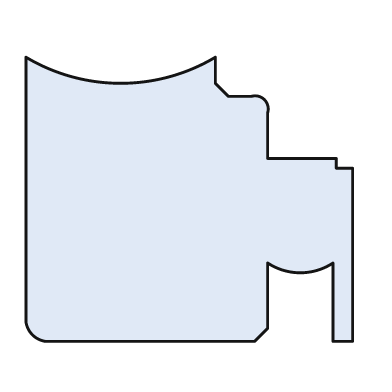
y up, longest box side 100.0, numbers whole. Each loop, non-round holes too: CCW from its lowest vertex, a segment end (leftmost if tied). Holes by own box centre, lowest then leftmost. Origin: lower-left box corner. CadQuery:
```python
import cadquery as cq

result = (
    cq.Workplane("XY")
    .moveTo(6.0, 0.0)
    .lineTo(70.0, 0.0)
    .lineTo(74.0, 4.0)
    .lineTo(74.0, 24.0)
    .threePointArc((84.0, 21.0), (94.0, 24.0))
    .lineTo(94.0, 0.0)
    .lineTo(100.0, 0.0)
    .lineTo(100.0, 53.0)
    .lineTo(95.0, 53.0)
    .lineTo(95.0, 56.0)
    .lineTo(74.0, 56.0)
    .lineTo(74.0, 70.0)
    .threePointArc((73.0, 74.0), (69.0, 75.0))
    .lineTo(62.0, 75.0)
    .lineTo(58.0, 79.0)
    .lineTo(58.0, 87.0)
    .threePointArc((29.0, 79.0), (0.0, 87.0))
    .lineTo(0.0, 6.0)
    .threePointArc((2.0, 2.0), (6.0, 0.0))
    .close()
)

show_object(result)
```